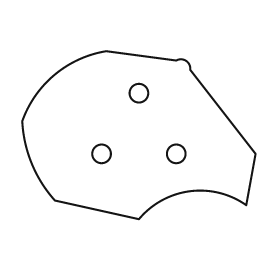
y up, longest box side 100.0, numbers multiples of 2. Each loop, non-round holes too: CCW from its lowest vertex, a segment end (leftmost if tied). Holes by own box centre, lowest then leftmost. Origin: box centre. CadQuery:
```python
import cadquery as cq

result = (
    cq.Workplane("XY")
    .moveTo(0.0, -36.0)
    .threePointArc((22.0, -24.0), (46.0, -30.0))
    .lineTo(50.0, -8.0)
    .lineTo(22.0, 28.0)
    .threePointArc((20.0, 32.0), (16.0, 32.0))
    .lineTo(-14.0, 36.0)
    .threePointArc((-36.0, 26.0), (-50.0, 6.0))
    .threePointArc((-46.0, -12.0), (-36.0, -28.0))
    .close()
    .moveTo(-16.0, -8.0)
    .circle(4.0)
    .moveTo(16.0, -8.0)
    .circle(4.0)
    .moveTo(0.0, 18.0)
    .circle(4.0)
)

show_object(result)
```